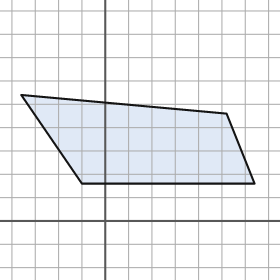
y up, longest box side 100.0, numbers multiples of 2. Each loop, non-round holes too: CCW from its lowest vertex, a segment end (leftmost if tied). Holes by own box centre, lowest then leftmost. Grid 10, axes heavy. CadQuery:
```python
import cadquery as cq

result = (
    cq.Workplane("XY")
    .moveTo(-10.0, 16.0)
    .lineTo(64.0, 16.0)
    .lineTo(52.0, 46.0)
    .lineTo(-36.0, 54.0)
    .close()
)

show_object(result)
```